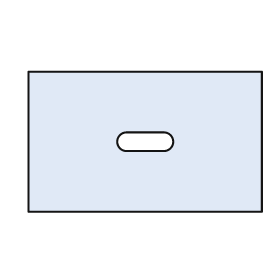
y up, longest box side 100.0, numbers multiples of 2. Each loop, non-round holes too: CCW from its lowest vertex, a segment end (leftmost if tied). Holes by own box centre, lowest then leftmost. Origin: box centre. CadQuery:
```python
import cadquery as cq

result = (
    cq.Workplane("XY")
    .moveTo(-50.0, -30.0)
    .lineTo(50.0, -30.0)
    .lineTo(50.0, 30.0)
    .lineTo(-50.0, 30.0)
    .close()
    .moveTo(-8.0, -4.0)
    .lineTo(8.0, -4.0)
    .threePointArc((12.0, 0.0), (8.0, 4.0))
    .lineTo(-8.0, 4.0)
    .threePointArc((-12.0, 0.0), (-8.0, -4.0))
    .close()
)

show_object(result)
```